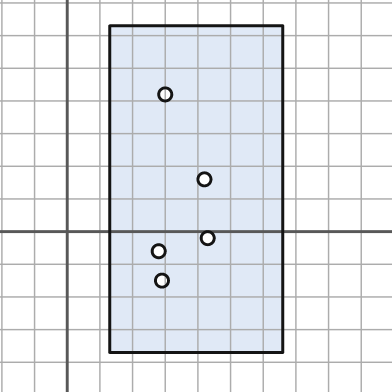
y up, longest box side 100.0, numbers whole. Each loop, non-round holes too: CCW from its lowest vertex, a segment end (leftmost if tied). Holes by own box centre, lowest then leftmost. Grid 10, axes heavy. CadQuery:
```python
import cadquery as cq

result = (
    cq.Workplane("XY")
    .moveTo(13.0, -37.0)
    .lineTo(66.0, -37.0)
    .lineTo(66.0, 63.0)
    .lineTo(13.0, 63.0)
    .close()
    .moveTo(29.0, -15.0)
    .circle(2.0)
    .moveTo(28.0, -6.0)
    .circle(2.0)
    .moveTo(43.0, -2.0)
    .circle(2.0)
    .moveTo(42.0, 16.0)
    .circle(2.0)
    .moveTo(30.0, 42.0)
    .circle(2.0)
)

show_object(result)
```